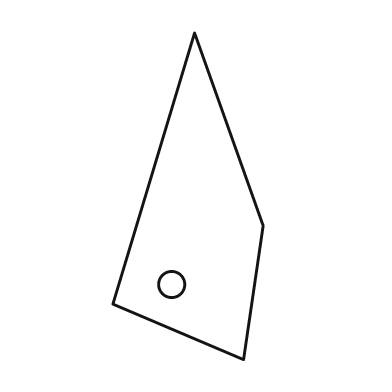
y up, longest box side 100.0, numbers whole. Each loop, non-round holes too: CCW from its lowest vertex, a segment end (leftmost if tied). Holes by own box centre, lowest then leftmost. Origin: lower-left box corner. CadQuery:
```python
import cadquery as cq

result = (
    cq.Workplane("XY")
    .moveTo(40.0, 0.0)
    .lineTo(46.0, 41.0)
    .lineTo(25.0, 100.0)
    .lineTo(0.0, 17.0)
    .close()
    .moveTo(18.0, 23.0)
    .circle(4.0)
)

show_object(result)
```